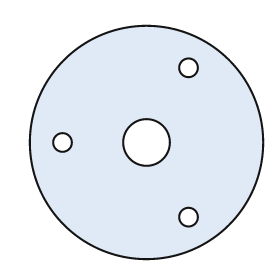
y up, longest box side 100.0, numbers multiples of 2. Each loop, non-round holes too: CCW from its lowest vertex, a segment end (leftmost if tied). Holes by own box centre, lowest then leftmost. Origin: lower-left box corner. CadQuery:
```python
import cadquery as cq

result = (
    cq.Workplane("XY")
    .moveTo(50.0, 50.0)
    .circle(50.0)
    .moveTo(68.0, 18.0)
    .circle(4.0)
    .moveTo(14.0, 50.0)
    .circle(4.0)
    .moveTo(50.0, 50.0)
    .circle(10.0)
    .moveTo(68.0, 82.0)
    .circle(4.0)
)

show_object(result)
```